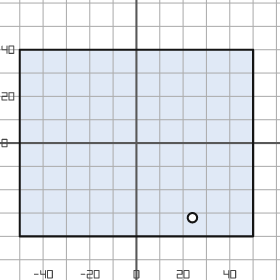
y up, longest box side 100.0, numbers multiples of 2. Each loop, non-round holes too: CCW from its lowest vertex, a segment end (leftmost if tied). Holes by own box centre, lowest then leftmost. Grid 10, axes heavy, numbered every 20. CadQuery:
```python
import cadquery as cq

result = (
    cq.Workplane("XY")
    .moveTo(-50.0, -40.0)
    .lineTo(50.0, -40.0)
    .lineTo(50.0, 40.0)
    .lineTo(-50.0, 40.0)
    .close()
    .moveTo(24.0, -32.0)
    .circle(2.0)
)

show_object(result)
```